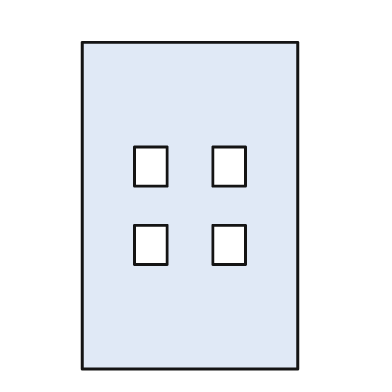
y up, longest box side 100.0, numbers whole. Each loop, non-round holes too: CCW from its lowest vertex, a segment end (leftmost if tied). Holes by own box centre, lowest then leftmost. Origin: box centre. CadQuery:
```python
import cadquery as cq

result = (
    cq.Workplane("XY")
    .moveTo(-33.0, -50.0)
    .lineTo(33.0, -50.0)
    .lineTo(33.0, 50.0)
    .lineTo(-33.0, 50.0)
    .close()
    .moveTo(-17.0, -18.0)
    .lineTo(-7.0, -18.0)
    .lineTo(-7.0, -6.0)
    .lineTo(-17.0, -6.0)
    .close()
    .moveTo(7.0, -18.0)
    .lineTo(17.0, -18.0)
    .lineTo(17.0, -6.0)
    .lineTo(7.0, -6.0)
    .close()
    .moveTo(-17.0, 6.0)
    .lineTo(-7.0, 6.0)
    .lineTo(-7.0, 18.0)
    .lineTo(-17.0, 18.0)
    .close()
    .moveTo(7.0, 6.0)
    .lineTo(17.0, 6.0)
    .lineTo(17.0, 18.0)
    .lineTo(7.0, 18.0)
    .close()
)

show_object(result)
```